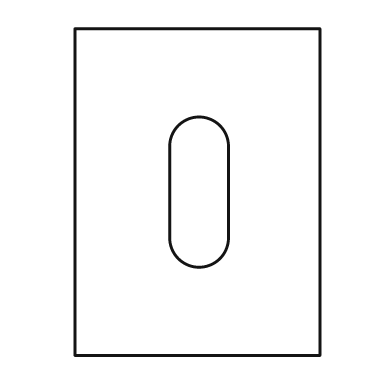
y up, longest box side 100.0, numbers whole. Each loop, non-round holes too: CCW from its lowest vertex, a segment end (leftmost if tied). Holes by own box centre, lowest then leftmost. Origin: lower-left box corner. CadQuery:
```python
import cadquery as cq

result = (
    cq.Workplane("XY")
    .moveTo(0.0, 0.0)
    .lineTo(75.0, 0.0)
    .lineTo(75.0, 100.0)
    .lineTo(0.0, 100.0)
    .close()
    .moveTo(29.0, 36.0)
    .threePointArc((38.0, 27.0), (47.0, 36.0))
    .lineTo(47.0, 64.0)
    .threePointArc((38.0, 73.0), (29.0, 64.0))
    .close()
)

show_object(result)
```